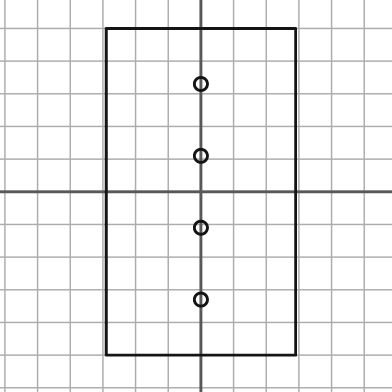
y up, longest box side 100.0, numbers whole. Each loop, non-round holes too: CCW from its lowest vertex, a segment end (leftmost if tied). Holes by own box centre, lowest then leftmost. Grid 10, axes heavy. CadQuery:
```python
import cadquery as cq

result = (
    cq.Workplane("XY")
    .moveTo(-29.0, -50.0)
    .lineTo(29.0, -50.0)
    .lineTo(29.0, 50.0)
    .lineTo(-29.0, 50.0)
    .close()
    .moveTo(0.0, -33.0)
    .circle(2.0)
    .moveTo(0.0, -11.0)
    .circle(2.0)
    .moveTo(0.0, 11.0)
    .circle(2.0)
    .moveTo(0.0, 33.0)
    .circle(2.0)
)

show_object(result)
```